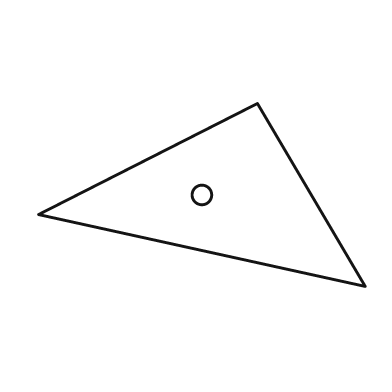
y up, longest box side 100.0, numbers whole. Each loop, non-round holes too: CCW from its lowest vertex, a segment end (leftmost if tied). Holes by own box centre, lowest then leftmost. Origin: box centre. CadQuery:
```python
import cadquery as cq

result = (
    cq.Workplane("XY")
    .moveTo(50.0, -28.0)
    .lineTo(17.0, 28.0)
    .lineTo(-50.0, -6.0)
    .close()
    .moveTo(0.0, 0.0)
    .circle(3.0)
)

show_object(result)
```